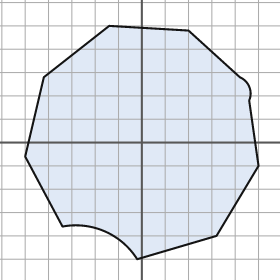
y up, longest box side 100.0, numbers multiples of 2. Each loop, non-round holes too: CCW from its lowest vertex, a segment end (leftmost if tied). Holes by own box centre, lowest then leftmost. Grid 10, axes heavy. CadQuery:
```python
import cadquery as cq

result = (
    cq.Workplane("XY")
    .moveTo(-2.0, -50.0)
    .lineTo(32.0, -40.0)
    .lineTo(50.0, -10.0)
    .lineTo(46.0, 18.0)
    .threePointArc((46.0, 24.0), (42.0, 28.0))
    .lineTo(20.0, 48.0)
    .lineTo(-14.0, 50.0)
    .lineTo(-42.0, 28.0)
    .lineTo(-50.0, -6.0)
    .lineTo(-34.0, -36.0)
    .threePointArc((-16.0, -38.0), (-2.0, -50.0))
    .close()
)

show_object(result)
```